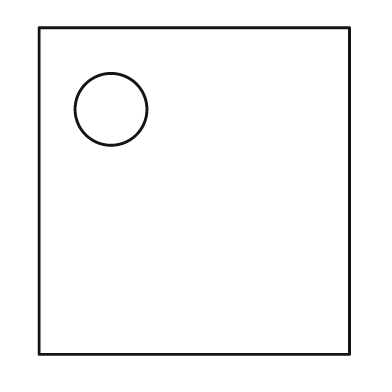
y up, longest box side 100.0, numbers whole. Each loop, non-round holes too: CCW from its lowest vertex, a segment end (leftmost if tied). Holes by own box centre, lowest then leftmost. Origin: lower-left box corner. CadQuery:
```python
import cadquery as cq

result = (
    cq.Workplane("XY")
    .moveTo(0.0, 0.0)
    .lineTo(95.0, 0.0)
    .lineTo(95.0, 100.0)
    .lineTo(0.0, 100.0)
    .close()
    .moveTo(22.0, 75.0)
    .circle(11.0)
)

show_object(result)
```